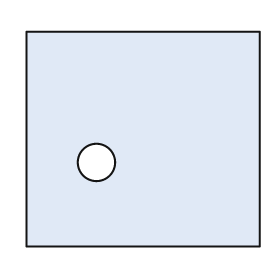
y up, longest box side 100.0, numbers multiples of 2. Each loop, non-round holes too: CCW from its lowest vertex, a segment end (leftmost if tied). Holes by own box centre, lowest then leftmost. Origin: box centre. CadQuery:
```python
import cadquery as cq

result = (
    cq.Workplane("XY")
    .moveTo(-50.0, -46.0)
    .lineTo(50.0, -46.0)
    .lineTo(50.0, 46.0)
    .lineTo(-50.0, 46.0)
    .close()
    .moveTo(-20.0, -10.0)
    .circle(8.0)
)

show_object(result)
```